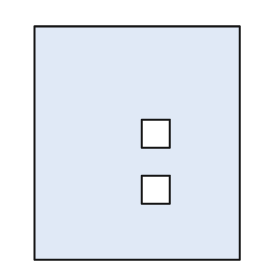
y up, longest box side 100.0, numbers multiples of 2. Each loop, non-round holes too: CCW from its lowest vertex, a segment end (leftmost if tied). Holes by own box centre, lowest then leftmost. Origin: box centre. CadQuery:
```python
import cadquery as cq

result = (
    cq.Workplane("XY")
    .moveTo(-44.0, -50.0)
    .lineTo(44.0, -50.0)
    .lineTo(44.0, 50.0)
    .lineTo(-44.0, 50.0)
    .close()
    .moveTo(2.0, -26.0)
    .lineTo(14.0, -26.0)
    .lineTo(14.0, -14.0)
    .lineTo(2.0, -14.0)
    .close()
    .moveTo(2.0, -2.0)
    .lineTo(14.0, -2.0)
    .lineTo(14.0, 10.0)
    .lineTo(2.0, 10.0)
    .close()
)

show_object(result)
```